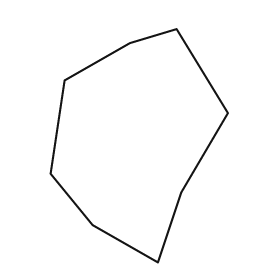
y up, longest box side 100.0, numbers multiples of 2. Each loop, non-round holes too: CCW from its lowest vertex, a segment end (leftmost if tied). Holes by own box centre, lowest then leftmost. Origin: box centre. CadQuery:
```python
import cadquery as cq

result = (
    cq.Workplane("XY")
    .moveTo(8.0, -50.0)
    .lineTo(18.0, -20.0)
    .lineTo(38.0, 14.0)
    .lineTo(16.0, 50.0)
    .lineTo(-4.0, 44.0)
    .lineTo(-32.0, 28.0)
    .lineTo(-38.0, -12.0)
    .lineTo(-20.0, -34.0)
    .close()
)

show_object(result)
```